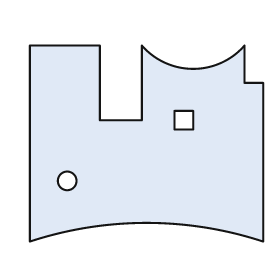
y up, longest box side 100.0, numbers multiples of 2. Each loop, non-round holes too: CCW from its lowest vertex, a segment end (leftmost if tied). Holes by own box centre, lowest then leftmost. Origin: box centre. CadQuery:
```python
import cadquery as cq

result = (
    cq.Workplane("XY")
    .moveTo(-50.0, -42.0)
    .threePointArc((0.0, -34.0), (50.0, -42.0))
    .lineTo(50.0, 26.0)
    .lineTo(42.0, 26.0)
    .lineTo(42.0, 42.0)
    .threePointArc((20.0, 32.0), (-2.0, 42.0))
    .lineTo(-2.0, 10.0)
    .lineTo(-20.0, 10.0)
    .lineTo(-20.0, 42.0)
    .lineTo(-50.0, 42.0)
    .close()
    .moveTo(-34.0, -16.0)
    .circle(4.0)
    .moveTo(12.0, 6.0)
    .lineTo(20.0, 6.0)
    .lineTo(20.0, 14.0)
    .lineTo(12.0, 14.0)
    .close()
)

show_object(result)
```